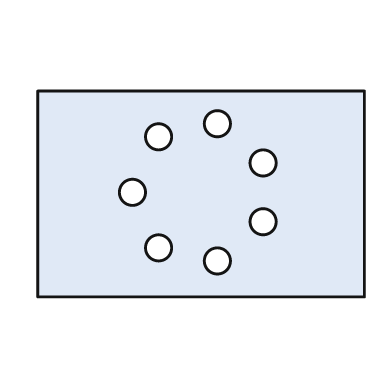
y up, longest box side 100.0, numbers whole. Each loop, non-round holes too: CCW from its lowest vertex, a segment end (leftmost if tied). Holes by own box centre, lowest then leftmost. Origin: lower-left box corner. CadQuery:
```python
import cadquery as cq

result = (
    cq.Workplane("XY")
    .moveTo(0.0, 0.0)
    .lineTo(100.0, 0.0)
    .lineTo(100.0, 63.0)
    .lineTo(0.0, 63.0)
    .close()
    .moveTo(55.0, 11.0)
    .circle(4.0)
    .moveTo(37.0, 15.0)
    .circle(4.0)
    .moveTo(69.0, 23.0)
    .circle(4.0)
    .moveTo(29.0, 32.0)
    .circle(4.0)
    .moveTo(69.0, 41.0)
    .circle(4.0)
    .moveTo(37.0, 49.0)
    .circle(4.0)
    .moveTo(55.0, 53.0)
    .circle(4.0)
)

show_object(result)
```